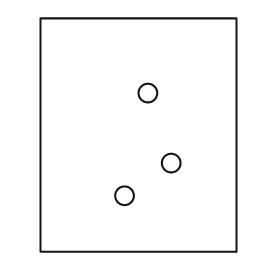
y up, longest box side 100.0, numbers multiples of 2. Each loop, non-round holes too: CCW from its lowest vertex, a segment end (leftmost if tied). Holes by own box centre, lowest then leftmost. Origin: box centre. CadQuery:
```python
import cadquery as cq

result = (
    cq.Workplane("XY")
    .moveTo(-42.0, -50.0)
    .lineTo(42.0, -50.0)
    .lineTo(42.0, 50.0)
    .lineTo(-42.0, 50.0)
    .close()
    .moveTo(-6.0, -26.0)
    .circle(4.0)
    .moveTo(14.0, -12.0)
    .circle(4.0)
    .moveTo(4.0, 18.0)
    .circle(4.0)
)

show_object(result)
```